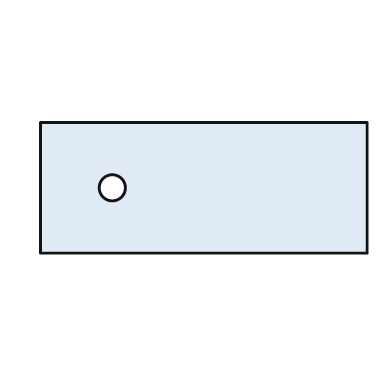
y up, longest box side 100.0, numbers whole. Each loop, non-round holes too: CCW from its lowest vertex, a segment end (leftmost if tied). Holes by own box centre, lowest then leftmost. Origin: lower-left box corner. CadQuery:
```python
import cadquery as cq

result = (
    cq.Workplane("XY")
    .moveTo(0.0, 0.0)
    .lineTo(100.0, 0.0)
    .lineTo(100.0, 40.0)
    .lineTo(0.0, 40.0)
    .close()
    .moveTo(22.0, 20.0)
    .circle(4.0)
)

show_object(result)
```